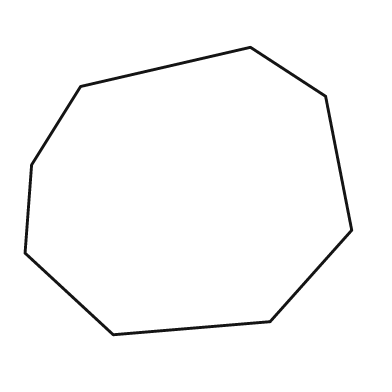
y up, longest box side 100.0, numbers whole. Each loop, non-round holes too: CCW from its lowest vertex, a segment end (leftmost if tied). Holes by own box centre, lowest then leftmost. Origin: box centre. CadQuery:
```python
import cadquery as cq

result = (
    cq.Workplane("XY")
    .moveTo(-23.0, -44.0)
    .lineTo(25.0, -40.0)
    .lineTo(50.0, -12.0)
    .lineTo(42.0, 29.0)
    .lineTo(19.0, 44.0)
    .lineTo(-33.0, 32.0)
    .lineTo(-48.0, 8.0)
    .lineTo(-50.0, -19.0)
    .close()
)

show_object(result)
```